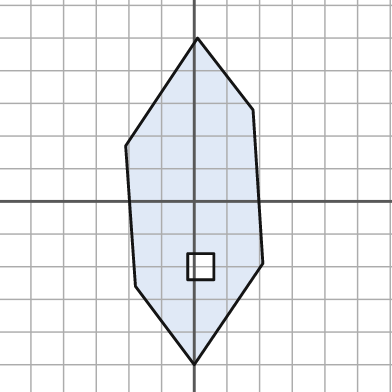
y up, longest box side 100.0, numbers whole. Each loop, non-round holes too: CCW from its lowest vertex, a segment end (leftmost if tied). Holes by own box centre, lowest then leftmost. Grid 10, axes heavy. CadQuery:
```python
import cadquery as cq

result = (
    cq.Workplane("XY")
    .moveTo(0.0, -50.0)
    .lineTo(21.0, -19.0)
    .lineTo(18.0, 28.0)
    .lineTo(1.0, 50.0)
    .lineTo(-21.0, 17.0)
    .lineTo(-18.0, -26.0)
    .close()
    .moveTo(-2.0, -24.0)
    .lineTo(6.0, -24.0)
    .lineTo(6.0, -16.0)
    .lineTo(-2.0, -16.0)
    .close()
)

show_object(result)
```